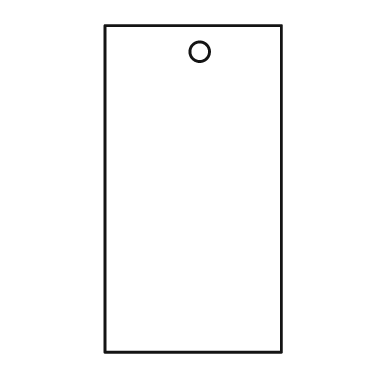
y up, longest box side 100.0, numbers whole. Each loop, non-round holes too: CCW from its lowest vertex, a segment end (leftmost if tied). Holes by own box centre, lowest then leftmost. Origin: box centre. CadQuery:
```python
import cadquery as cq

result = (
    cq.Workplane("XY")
    .moveTo(-27.0, -50.0)
    .lineTo(27.0, -50.0)
    .lineTo(27.0, 50.0)
    .lineTo(-27.0, 50.0)
    .close()
    .moveTo(2.0, 42.0)
    .circle(3.0)
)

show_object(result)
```